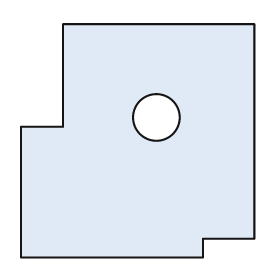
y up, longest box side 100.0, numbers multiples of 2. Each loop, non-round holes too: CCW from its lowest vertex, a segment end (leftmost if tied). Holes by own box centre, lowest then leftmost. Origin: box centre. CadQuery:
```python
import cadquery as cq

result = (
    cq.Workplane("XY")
    .moveTo(-50.0, -50.0)
    .lineTo(28.0, -50.0)
    .lineTo(28.0, -42.0)
    .lineTo(50.0, -42.0)
    .lineTo(50.0, 50.0)
    .lineTo(-32.0, 50.0)
    .lineTo(-32.0, 6.0)
    .lineTo(-50.0, 6.0)
    .close()
    .moveTo(8.0, 10.0)
    .circle(10.0)
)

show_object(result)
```